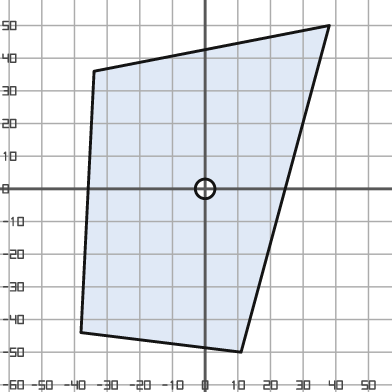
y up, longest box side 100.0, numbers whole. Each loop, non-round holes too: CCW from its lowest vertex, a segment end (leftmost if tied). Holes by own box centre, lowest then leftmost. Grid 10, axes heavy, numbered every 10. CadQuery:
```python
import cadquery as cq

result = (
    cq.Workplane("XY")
    .moveTo(11.0, -50.0)
    .lineTo(38.0, 50.0)
    .lineTo(-34.0, 36.0)
    .lineTo(-38.0, -44.0)
    .close()
    .moveTo(0.0, 0.0)
    .circle(3.0)
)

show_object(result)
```